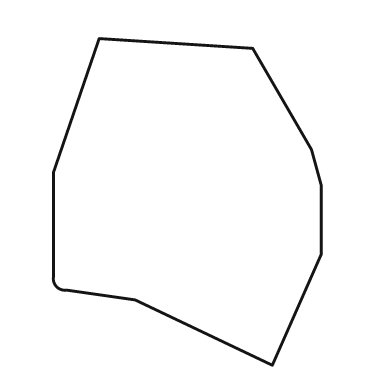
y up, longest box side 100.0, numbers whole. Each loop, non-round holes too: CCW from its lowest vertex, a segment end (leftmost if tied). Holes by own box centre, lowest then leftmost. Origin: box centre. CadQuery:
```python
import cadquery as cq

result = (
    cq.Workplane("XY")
    .moveTo(26.0, -50.0)
    .lineTo(41.0, -16.0)
    .lineTo(41.0, 5.0)
    .lineTo(38.0, 16.0)
    .lineTo(20.0, 47.0)
    .lineTo(-27.0, 50.0)
    .lineTo(-41.0, 9.0)
    .lineTo(-41.0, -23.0)
    .threePointArc((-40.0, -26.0), (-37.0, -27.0))
    .lineTo(-16.0, -30.0)
    .close()
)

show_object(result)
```